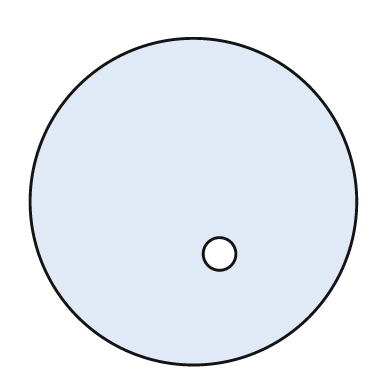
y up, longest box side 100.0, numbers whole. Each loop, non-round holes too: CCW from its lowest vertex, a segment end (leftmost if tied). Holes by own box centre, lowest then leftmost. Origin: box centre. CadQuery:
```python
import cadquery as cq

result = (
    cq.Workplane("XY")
    .moveTo(0.0, 0.0)
    .circle(50.0)
    .moveTo(8.0, -16.0)
    .circle(5.0)
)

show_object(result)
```